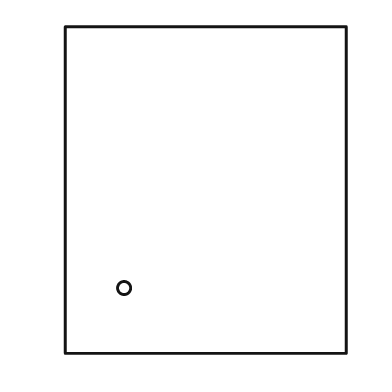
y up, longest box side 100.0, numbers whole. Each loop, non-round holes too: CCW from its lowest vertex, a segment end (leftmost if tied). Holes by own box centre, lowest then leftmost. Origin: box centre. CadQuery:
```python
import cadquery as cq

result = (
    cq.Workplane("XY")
    .moveTo(-43.0, -50.0)
    .lineTo(43.0, -50.0)
    .lineTo(43.0, 50.0)
    .lineTo(-43.0, 50.0)
    .close()
    .moveTo(-25.0, -30.0)
    .circle(2.0)
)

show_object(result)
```